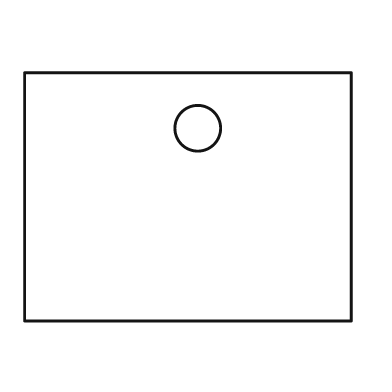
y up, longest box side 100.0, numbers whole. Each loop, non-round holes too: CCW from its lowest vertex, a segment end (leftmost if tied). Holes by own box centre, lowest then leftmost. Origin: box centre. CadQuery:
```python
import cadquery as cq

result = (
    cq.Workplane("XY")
    .moveTo(-50.0, -38.0)
    .lineTo(50.0, -38.0)
    .lineTo(50.0, 38.0)
    .lineTo(-50.0, 38.0)
    .close()
    .moveTo(3.0, 21.0)
    .circle(7.0)
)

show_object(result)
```